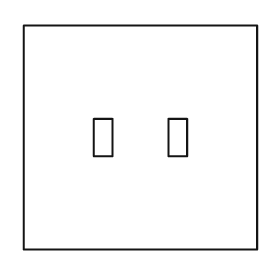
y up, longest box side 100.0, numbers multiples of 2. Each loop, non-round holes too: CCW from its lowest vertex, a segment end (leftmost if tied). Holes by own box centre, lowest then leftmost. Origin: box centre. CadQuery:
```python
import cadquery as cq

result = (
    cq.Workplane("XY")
    .moveTo(-50.0, -48.0)
    .lineTo(50.0, -48.0)
    .lineTo(50.0, 48.0)
    .lineTo(-50.0, 48.0)
    .close()
    .moveTo(-20.0, -8.0)
    .lineTo(-12.0, -8.0)
    .lineTo(-12.0, 8.0)
    .lineTo(-20.0, 8.0)
    .close()
    .moveTo(12.0, -8.0)
    .lineTo(20.0, -8.0)
    .lineTo(20.0, 8.0)
    .lineTo(12.0, 8.0)
    .close()
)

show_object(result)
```